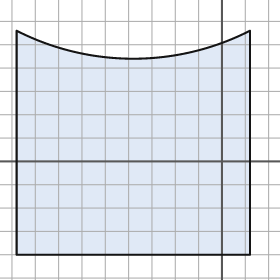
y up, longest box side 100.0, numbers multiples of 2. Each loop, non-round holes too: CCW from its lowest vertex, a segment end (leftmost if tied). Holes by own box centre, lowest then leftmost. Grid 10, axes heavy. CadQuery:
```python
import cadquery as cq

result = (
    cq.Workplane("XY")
    .moveTo(-88.0, -40.0)
    .lineTo(12.0, -40.0)
    .lineTo(12.0, 56.0)
    .threePointArc((-38.0, 44.0), (-88.0, 56.0))
    .close()
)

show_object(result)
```